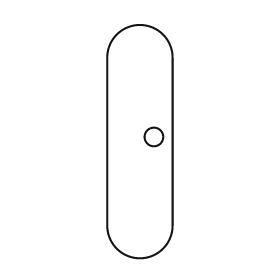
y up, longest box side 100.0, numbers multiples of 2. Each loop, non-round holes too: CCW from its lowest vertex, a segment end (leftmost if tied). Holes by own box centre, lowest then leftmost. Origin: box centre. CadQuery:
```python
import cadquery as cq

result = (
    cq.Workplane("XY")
    .moveTo(-14.0, -36.0)
    .threePointArc((0.0, -50.0), (14.0, -36.0))
    .lineTo(14.0, 36.0)
    .threePointArc((0.0, 50.0), (-14.0, 36.0))
    .close()
    .moveTo(6.0, 2.0)
    .circle(4.0)
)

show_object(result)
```